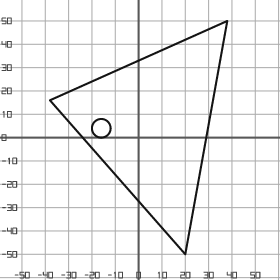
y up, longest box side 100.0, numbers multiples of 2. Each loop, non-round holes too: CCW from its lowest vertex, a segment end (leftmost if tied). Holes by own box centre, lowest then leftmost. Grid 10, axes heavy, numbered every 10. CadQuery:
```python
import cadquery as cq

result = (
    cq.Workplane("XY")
    .moveTo(20.0, -50.0)
    .lineTo(38.0, 50.0)
    .lineTo(-38.0, 16.0)
    .close()
    .moveTo(-16.0, 4.0)
    .circle(4.0)
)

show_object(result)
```